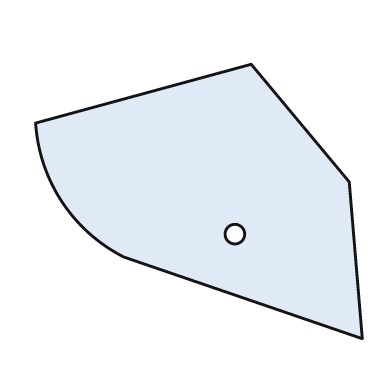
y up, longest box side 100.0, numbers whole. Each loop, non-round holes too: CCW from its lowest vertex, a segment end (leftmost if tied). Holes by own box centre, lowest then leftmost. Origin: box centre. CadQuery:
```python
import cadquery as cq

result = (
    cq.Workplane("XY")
    .moveTo(50.0, -42.0)
    .lineTo(46.0, 6.0)
    .lineTo(16.0, 42.0)
    .lineTo(-50.0, 24.0)
    .threePointArc((-42.0, 0.0), (-23.0, -17.0))
    .close()
    .moveTo(11.0, -10.0)
    .circle(3.0)
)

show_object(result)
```